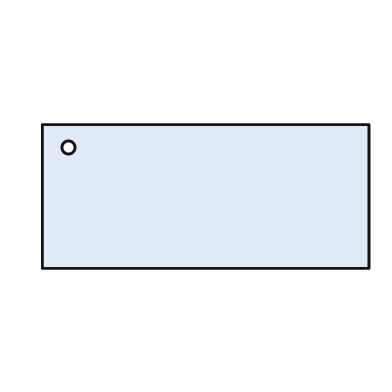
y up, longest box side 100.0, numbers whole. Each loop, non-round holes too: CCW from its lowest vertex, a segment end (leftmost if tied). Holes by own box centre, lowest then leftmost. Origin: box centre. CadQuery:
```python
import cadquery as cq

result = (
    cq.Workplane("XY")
    .moveTo(-50.0, -22.0)
    .lineTo(50.0, -22.0)
    .lineTo(50.0, 22.0)
    .lineTo(-50.0, 22.0)
    .close()
    .moveTo(-42.0, 15.0)
    .circle(2.0)
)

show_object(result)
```